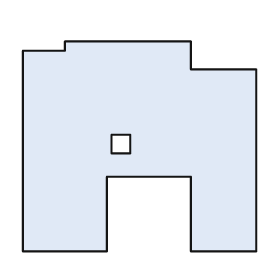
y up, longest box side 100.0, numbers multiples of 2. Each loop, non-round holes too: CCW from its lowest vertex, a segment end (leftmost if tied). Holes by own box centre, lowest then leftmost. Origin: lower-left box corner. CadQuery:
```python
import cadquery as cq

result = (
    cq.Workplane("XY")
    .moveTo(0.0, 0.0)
    .lineTo(36.0, 0.0)
    .lineTo(36.0, 32.0)
    .lineTo(72.0, 32.0)
    .lineTo(72.0, 0.0)
    .lineTo(100.0, 0.0)
    .lineTo(100.0, 78.0)
    .lineTo(72.0, 78.0)
    .lineTo(72.0, 90.0)
    .lineTo(18.0, 90.0)
    .lineTo(18.0, 86.0)
    .lineTo(0.0, 86.0)
    .close()
    .moveTo(38.0, 42.0)
    .lineTo(46.0, 42.0)
    .lineTo(46.0, 50.0)
    .lineTo(38.0, 50.0)
    .close()
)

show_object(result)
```